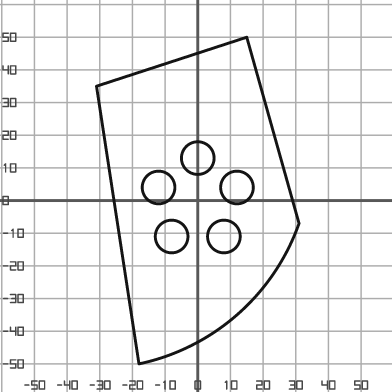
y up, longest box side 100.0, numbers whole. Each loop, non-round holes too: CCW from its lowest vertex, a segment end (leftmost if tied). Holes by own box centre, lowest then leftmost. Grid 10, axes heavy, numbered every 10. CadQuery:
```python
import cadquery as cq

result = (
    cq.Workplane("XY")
    .moveTo(-18.0, -50.0)
    .threePointArc((12.0, -35.0), (31.0, -7.0))
    .lineTo(15.0, 50.0)
    .lineTo(-31.0, 35.0)
    .close()
    .moveTo(-8.0, -11.0)
    .circle(5.0)
    .moveTo(8.0, -11.0)
    .circle(5.0)
    .moveTo(-12.0, 4.0)
    .circle(5.0)
    .moveTo(12.0, 4.0)
    .circle(5.0)
    .moveTo(0.0, 13.0)
    .circle(5.0)
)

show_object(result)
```